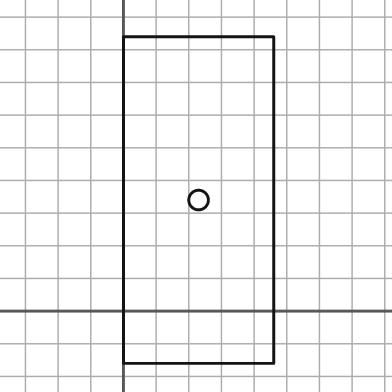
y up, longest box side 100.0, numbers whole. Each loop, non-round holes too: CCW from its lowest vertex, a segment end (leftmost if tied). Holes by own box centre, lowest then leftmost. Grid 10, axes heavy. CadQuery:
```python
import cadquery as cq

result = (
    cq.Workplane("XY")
    .moveTo(0.0, -16.0)
    .lineTo(46.0, -16.0)
    .lineTo(46.0, 84.0)
    .lineTo(0.0, 84.0)
    .close()
    .moveTo(23.0, 34.0)
    .circle(3.0)
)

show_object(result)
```